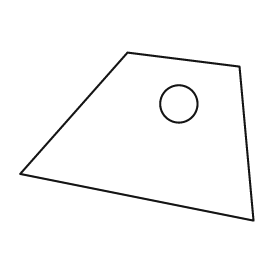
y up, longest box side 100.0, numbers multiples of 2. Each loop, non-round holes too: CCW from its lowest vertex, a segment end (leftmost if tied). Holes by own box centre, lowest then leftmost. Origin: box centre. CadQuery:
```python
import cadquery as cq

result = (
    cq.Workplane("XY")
    .moveTo(50.0, -36.0)
    .lineTo(44.0, 30.0)
    .lineTo(-4.0, 36.0)
    .lineTo(-50.0, -16.0)
    .close()
    .moveTo(18.0, 14.0)
    .circle(8.0)
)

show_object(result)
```